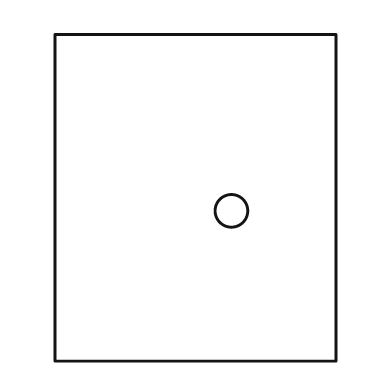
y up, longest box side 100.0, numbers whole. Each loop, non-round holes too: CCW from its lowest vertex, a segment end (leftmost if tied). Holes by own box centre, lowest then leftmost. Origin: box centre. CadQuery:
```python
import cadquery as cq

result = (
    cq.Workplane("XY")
    .moveTo(-43.0, -50.0)
    .lineTo(43.0, -50.0)
    .lineTo(43.0, 50.0)
    .lineTo(-43.0, 50.0)
    .close()
    .moveTo(11.0, -4.0)
    .circle(5.0)
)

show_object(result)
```